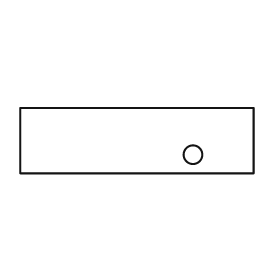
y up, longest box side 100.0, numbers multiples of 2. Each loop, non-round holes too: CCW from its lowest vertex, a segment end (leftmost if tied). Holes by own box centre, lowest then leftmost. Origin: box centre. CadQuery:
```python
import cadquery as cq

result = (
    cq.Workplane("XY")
    .moveTo(-50.0, -14.0)
    .lineTo(50.0, -14.0)
    .lineTo(50.0, 14.0)
    .lineTo(-50.0, 14.0)
    .close()
    .moveTo(24.0, -6.0)
    .circle(4.0)
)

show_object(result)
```